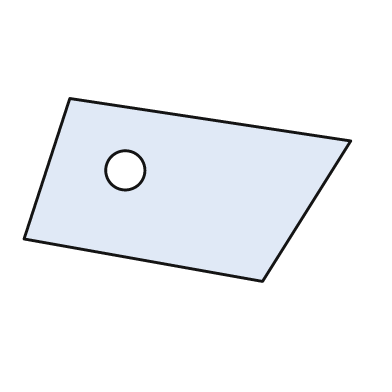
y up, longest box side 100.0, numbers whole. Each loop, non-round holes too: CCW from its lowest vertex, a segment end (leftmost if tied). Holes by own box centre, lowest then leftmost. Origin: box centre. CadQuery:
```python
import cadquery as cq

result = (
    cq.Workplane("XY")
    .moveTo(23.0, -28.0)
    .lineTo(50.0, 15.0)
    .lineTo(-36.0, 28.0)
    .lineTo(-50.0, -15.0)
    .close()
    .moveTo(-19.0, 6.0)
    .circle(6.0)
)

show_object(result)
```